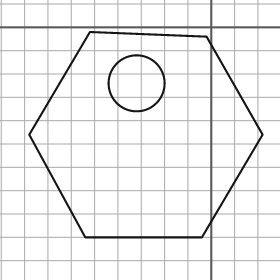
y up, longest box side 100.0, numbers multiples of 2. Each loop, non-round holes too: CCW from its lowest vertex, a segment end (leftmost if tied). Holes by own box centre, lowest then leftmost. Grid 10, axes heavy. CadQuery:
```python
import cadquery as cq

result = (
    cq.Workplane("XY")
    .moveTo(-54.0, -90.0)
    .lineTo(-4.0, -90.0)
    .lineTo(22.0, -46.0)
    .lineTo(-2.0, -4.0)
    .lineTo(-52.0, -2.0)
    .lineTo(-78.0, -46.0)
    .close()
    .moveTo(-32.0, -24.0)
    .circle(12.0)
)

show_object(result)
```